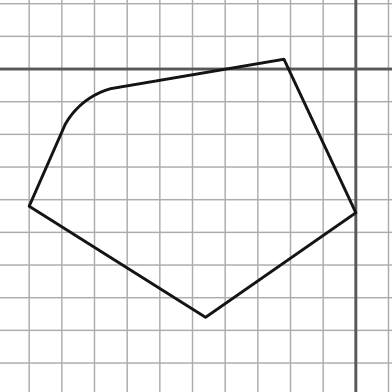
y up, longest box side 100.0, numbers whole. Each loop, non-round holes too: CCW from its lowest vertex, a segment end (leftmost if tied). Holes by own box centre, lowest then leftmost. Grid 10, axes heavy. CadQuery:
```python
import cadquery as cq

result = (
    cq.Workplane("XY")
    .moveTo(-46.0, -76.0)
    .lineTo(0.0, -44.0)
    .lineTo(-22.0, 3.0)
    .lineTo(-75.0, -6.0)
    .threePointArc((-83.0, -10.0), (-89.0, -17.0))
    .lineTo(-100.0, -42.0)
    .close()
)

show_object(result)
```